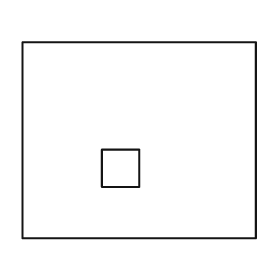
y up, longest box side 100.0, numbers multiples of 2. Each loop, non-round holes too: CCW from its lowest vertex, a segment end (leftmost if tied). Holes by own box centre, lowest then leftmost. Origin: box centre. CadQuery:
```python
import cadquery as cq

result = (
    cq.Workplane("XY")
    .moveTo(-50.0, -42.0)
    .lineTo(50.0, -42.0)
    .lineTo(50.0, 42.0)
    .lineTo(-50.0, 42.0)
    .close()
    .moveTo(-16.0, -20.0)
    .lineTo(0.0, -20.0)
    .lineTo(0.0, -4.0)
    .lineTo(-16.0, -4.0)
    .close()
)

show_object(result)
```